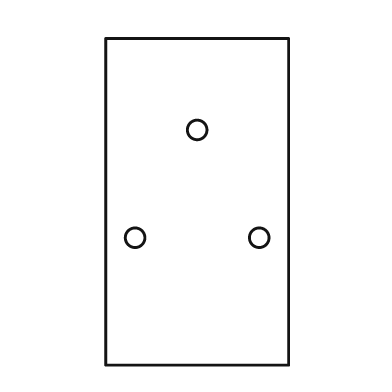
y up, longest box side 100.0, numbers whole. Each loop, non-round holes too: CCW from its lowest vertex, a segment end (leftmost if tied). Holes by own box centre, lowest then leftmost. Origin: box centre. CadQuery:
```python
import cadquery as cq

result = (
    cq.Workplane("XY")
    .moveTo(-28.0, -50.0)
    .lineTo(28.0, -50.0)
    .lineTo(28.0, 50.0)
    .lineTo(-28.0, 50.0)
    .close()
    .moveTo(-19.0, -11.0)
    .circle(3.0)
    .moveTo(19.0, -11.0)
    .circle(3.0)
    .moveTo(0.0, 22.0)
    .circle(3.0)
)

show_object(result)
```